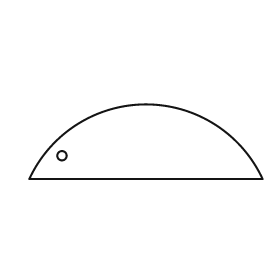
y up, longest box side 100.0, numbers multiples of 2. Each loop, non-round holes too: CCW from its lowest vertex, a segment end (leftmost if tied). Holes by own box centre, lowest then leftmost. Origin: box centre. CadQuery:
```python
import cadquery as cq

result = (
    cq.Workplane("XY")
    .moveTo(-50.0, -16.0)
    .lineTo(50.0, -16.0)
    .threePointArc((0.0, 16.0), (-50.0, -16.0))
    .close()
    .moveTo(-36.0, -6.0)
    .circle(2.0)
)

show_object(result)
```